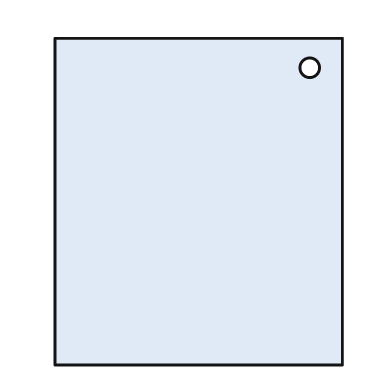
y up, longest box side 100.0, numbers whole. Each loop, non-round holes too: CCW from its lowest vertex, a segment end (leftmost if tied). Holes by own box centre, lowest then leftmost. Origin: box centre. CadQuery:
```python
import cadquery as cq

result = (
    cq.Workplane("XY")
    .moveTo(-44.0, -50.0)
    .lineTo(44.0, -50.0)
    .lineTo(44.0, 50.0)
    .lineTo(-44.0, 50.0)
    .close()
    .moveTo(34.0, 41.0)
    .circle(3.0)
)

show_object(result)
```